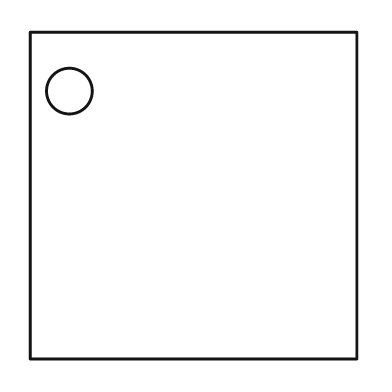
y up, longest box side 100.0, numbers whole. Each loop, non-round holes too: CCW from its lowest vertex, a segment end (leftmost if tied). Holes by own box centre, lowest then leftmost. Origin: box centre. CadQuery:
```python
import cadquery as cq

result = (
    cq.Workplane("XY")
    .moveTo(-50.0, -50.0)
    .lineTo(50.0, -50.0)
    .lineTo(50.0, 50.0)
    .lineTo(-50.0, 50.0)
    .close()
    .moveTo(-38.0, 32.0)
    .circle(7.0)
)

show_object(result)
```